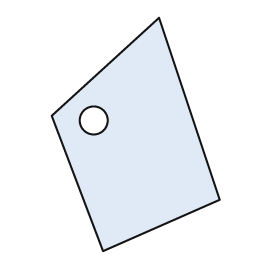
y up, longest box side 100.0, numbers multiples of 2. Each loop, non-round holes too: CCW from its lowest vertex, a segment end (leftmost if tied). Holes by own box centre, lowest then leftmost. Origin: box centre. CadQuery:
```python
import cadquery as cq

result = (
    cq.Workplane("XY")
    .moveTo(-14.0, -50.0)
    .lineTo(36.0, -28.0)
    .lineTo(10.0, 50.0)
    .lineTo(-36.0, 8.0)
    .close()
    .moveTo(-18.0, 6.0)
    .circle(6.0)
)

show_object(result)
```